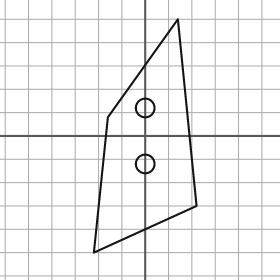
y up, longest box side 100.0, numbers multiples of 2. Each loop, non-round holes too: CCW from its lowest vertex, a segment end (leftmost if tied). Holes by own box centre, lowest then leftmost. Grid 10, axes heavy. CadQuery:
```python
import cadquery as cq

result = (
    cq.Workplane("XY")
    .moveTo(-22.0, -50.0)
    .lineTo(22.0, -30.0)
    .lineTo(14.0, 50.0)
    .lineTo(-16.0, 8.0)
    .close()
    .moveTo(0.0, -12.0)
    .circle(4.0)
    .moveTo(0.0, 12.0)
    .circle(4.0)
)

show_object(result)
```